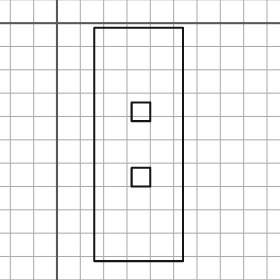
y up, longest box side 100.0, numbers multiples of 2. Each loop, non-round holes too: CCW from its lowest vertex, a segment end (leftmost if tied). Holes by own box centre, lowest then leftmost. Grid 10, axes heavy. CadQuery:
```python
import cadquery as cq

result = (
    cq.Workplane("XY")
    .moveTo(16.0, -102.0)
    .lineTo(54.0, -102.0)
    .lineTo(54.0, -2.0)
    .lineTo(16.0, -2.0)
    .close()
    .moveTo(32.0, -70.0)
    .lineTo(40.0, -70.0)
    .lineTo(40.0, -62.0)
    .lineTo(32.0, -62.0)
    .close()
    .moveTo(32.0, -42.0)
    .lineTo(40.0, -42.0)
    .lineTo(40.0, -34.0)
    .lineTo(32.0, -34.0)
    .close()
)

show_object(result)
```